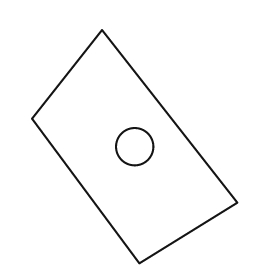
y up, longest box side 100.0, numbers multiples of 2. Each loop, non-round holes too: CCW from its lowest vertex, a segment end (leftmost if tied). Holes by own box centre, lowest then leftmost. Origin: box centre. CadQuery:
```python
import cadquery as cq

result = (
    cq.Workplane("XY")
    .moveTo(2.0, -50.0)
    .lineTo(44.0, -24.0)
    .lineTo(-14.0, 50.0)
    .lineTo(-44.0, 12.0)
    .close()
    .moveTo(0.0, 0.0)
    .circle(8.0)
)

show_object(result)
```